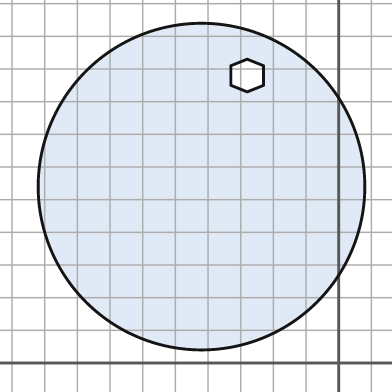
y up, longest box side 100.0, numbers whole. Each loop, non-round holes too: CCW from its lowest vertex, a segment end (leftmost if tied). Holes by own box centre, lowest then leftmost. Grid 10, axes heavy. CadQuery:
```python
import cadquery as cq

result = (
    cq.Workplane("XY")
    .moveTo(-42.0, 54.0)
    .circle(50.0)
    .moveTo(-28.0, 83.0)
    .lineTo(-23.0, 85.0)
    .lineTo(-23.0, 91.0)
    .lineTo(-28.0, 93.0)
    .lineTo(-33.0, 91.0)
    .lineTo(-33.0, 85.0)
    .close()
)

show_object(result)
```